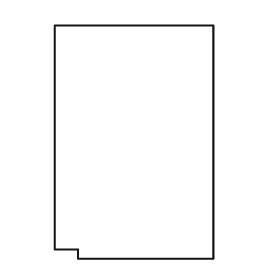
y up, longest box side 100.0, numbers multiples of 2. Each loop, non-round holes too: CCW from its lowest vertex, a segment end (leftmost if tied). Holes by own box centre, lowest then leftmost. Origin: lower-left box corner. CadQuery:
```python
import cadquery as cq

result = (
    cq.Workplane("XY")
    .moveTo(10.0, 0.0)
    .lineTo(68.0, 0.0)
    .lineTo(68.0, 100.0)
    .lineTo(0.0, 100.0)
    .lineTo(0.0, 4.0)
    .lineTo(10.0, 4.0)
    .close()
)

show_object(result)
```